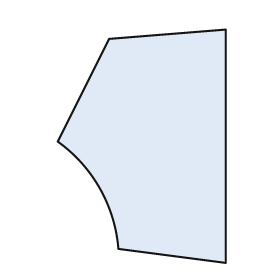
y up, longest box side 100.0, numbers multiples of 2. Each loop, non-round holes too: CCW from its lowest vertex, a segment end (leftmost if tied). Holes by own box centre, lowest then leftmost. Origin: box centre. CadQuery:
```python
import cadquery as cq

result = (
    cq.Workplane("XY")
    .moveTo(36.0, -50.0)
    .lineTo(36.0, 50.0)
    .lineTo(-14.0, 46.0)
    .lineTo(-36.0, 2.0)
    .threePointArc((-18.0, -18.0), (-10.0, -44.0))
    .close()
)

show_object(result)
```